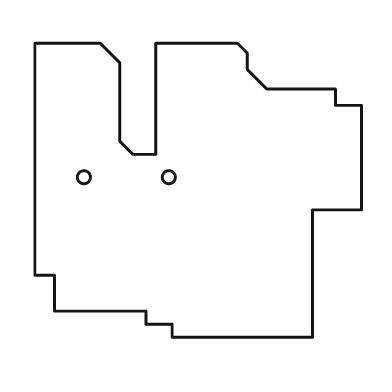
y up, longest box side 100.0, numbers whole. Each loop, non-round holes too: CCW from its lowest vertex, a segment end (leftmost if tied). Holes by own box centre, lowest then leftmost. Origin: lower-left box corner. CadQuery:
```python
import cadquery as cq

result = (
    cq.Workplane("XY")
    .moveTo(42.0, 0.0)
    .lineTo(85.0, 0.0)
    .lineTo(85.0, 39.0)
    .lineTo(100.0, 39.0)
    .lineTo(100.0, 71.0)
    .lineTo(92.0, 71.0)
    .lineTo(92.0, 76.0)
    .lineTo(71.0, 76.0)
    .lineTo(65.0, 82.0)
    .lineTo(65.0, 87.0)
    .lineTo(62.0, 90.0)
    .lineTo(37.0, 90.0)
    .lineTo(37.0, 56.0)
    .lineTo(30.0, 56.0)
    .lineTo(26.0, 60.0)
    .lineTo(26.0, 84.0)
    .lineTo(20.0, 90.0)
    .lineTo(0.0, 90.0)
    .lineTo(0.0, 19.0)
    .lineTo(6.0, 19.0)
    .lineTo(6.0, 8.0)
    .lineTo(34.0, 8.0)
    .lineTo(34.0, 4.0)
    .lineTo(42.0, 4.0)
    .close()
    .moveTo(15.0, 49.0)
    .circle(2.0)
    .moveTo(41.0, 49.0)
    .circle(2.0)
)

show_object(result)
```